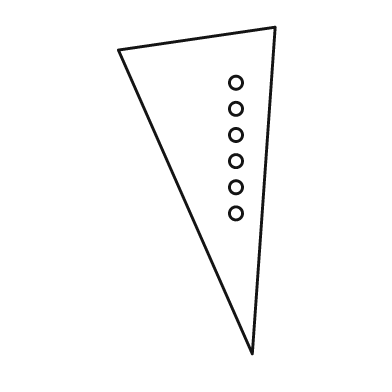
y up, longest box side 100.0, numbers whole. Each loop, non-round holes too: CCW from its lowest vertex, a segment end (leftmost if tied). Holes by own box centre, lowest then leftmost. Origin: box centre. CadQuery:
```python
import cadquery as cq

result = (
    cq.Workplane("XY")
    .moveTo(17.0, -50.0)
    .lineTo(24.0, 50.0)
    .lineTo(-24.0, 43.0)
    .close()
    .moveTo(12.0, -7.0)
    .circle(2.0)
    .moveTo(12.0, 1.0)
    .circle(2.0)
    .moveTo(12.0, 9.0)
    .circle(2.0)
    .moveTo(12.0, 17.0)
    .circle(2.0)
    .moveTo(12.0, 25.0)
    .circle(2.0)
    .moveTo(12.0, 33.0)
    .circle(2.0)
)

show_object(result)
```